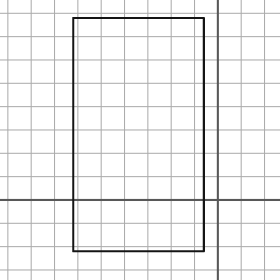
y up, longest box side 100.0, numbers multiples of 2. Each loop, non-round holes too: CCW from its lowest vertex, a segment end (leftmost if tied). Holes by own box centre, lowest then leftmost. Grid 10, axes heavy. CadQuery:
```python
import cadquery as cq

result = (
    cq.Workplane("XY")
    .moveTo(-62.0, -22.0)
    .lineTo(-6.0, -22.0)
    .lineTo(-6.0, 78.0)
    .lineTo(-62.0, 78.0)
    .close()
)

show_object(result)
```